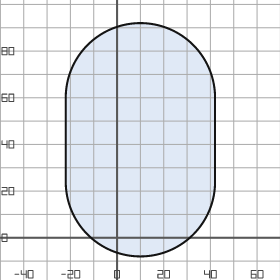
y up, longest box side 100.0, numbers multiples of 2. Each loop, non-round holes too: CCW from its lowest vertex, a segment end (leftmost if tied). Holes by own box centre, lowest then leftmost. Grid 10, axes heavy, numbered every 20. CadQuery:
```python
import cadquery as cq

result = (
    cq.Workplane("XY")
    .moveTo(-22.0, 24.0)
    .threePointArc((10.0, -8.0), (42.0, 24.0))
    .lineTo(42.0, 60.0)
    .threePointArc((10.0, 92.0), (-22.0, 60.0))
    .close()
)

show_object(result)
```